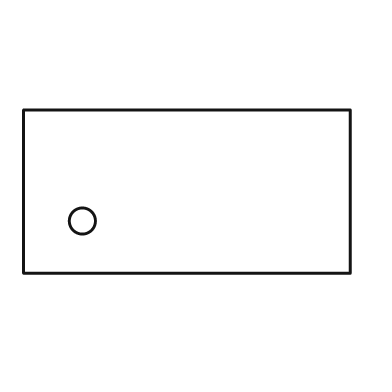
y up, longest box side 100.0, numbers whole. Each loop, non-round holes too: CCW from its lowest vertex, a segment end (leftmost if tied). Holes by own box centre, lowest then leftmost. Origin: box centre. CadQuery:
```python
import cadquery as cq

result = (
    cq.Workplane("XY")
    .moveTo(-50.0, -25.0)
    .lineTo(50.0, -25.0)
    .lineTo(50.0, 25.0)
    .lineTo(-50.0, 25.0)
    .close()
    .moveTo(-32.0, -9.0)
    .circle(4.0)
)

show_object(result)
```